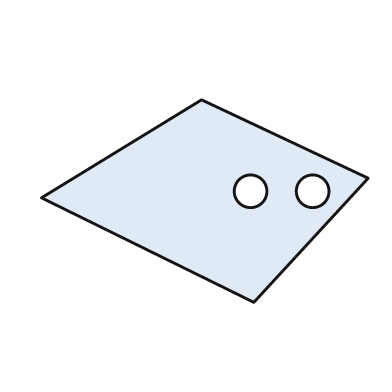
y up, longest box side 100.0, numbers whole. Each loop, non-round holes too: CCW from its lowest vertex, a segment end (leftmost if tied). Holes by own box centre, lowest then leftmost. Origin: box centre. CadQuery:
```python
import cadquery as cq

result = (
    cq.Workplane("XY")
    .moveTo(15.0, -31.0)
    .lineTo(50.0, 7.0)
    .lineTo(-1.0, 31.0)
    .lineTo(-50.0, 1.0)
    .close()
    .moveTo(14.0, 3.0)
    .circle(5.0)
    .moveTo(33.0, 3.0)
    .circle(5.0)
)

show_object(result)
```